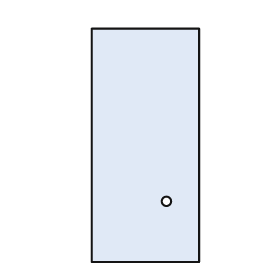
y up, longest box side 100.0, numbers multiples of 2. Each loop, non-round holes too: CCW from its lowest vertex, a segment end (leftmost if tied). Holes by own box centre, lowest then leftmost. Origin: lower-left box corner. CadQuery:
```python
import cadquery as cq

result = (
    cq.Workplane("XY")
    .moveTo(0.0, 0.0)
    .lineTo(46.0, 0.0)
    .lineTo(46.0, 100.0)
    .lineTo(0.0, 100.0)
    .close()
    .moveTo(32.0, 26.0)
    .circle(2.0)
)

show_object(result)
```